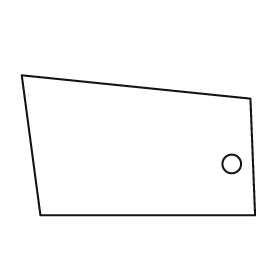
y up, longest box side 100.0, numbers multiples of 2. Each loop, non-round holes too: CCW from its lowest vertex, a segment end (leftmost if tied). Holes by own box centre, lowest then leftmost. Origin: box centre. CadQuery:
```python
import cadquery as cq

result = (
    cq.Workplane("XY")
    .moveTo(-42.0, -30.0)
    .lineTo(50.0, -30.0)
    .lineTo(48.0, 20.0)
    .lineTo(-50.0, 30.0)
    .close()
    .moveTo(40.0, -8.0)
    .circle(4.0)
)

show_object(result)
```